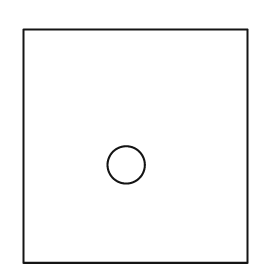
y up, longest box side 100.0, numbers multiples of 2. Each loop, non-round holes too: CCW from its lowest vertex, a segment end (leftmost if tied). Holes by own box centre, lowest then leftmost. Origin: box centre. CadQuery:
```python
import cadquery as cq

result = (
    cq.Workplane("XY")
    .moveTo(-48.0, -50.0)
    .lineTo(48.0, -50.0)
    .lineTo(48.0, 50.0)
    .lineTo(-48.0, 50.0)
    .close()
    .moveTo(-4.0, -8.0)
    .circle(8.0)
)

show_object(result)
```